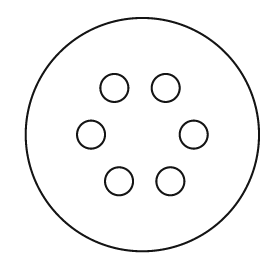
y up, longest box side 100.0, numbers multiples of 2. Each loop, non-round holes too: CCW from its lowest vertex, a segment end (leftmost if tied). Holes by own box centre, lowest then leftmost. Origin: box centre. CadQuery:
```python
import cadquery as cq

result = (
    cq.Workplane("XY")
    .moveTo(0.0, 0.0)
    .circle(50.0)
    .moveTo(-10.0, -20.0)
    .circle(6.0)
    .moveTo(12.0, -20.0)
    .circle(6.0)
    .moveTo(-22.0, 0.0)
    .circle(6.0)
    .moveTo(22.0, 0.0)
    .circle(6.0)
    .moveTo(-12.0, 20.0)
    .circle(6.0)
    .moveTo(10.0, 20.0)
    .circle(6.0)
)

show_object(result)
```